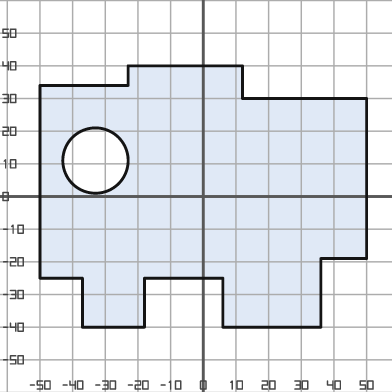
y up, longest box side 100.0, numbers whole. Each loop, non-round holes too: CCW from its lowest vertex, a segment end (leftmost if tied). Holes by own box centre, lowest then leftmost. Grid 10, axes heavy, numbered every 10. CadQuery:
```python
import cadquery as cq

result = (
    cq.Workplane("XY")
    .moveTo(-37.0, -40.0)
    .lineTo(-18.0, -40.0)
    .lineTo(-18.0, -25.0)
    .lineTo(6.0, -25.0)
    .lineTo(6.0, -40.0)
    .lineTo(36.0, -40.0)
    .lineTo(36.0, -19.0)
    .lineTo(50.0, -19.0)
    .lineTo(50.0, 30.0)
    .lineTo(12.0, 30.0)
    .lineTo(12.0, 40.0)
    .lineTo(-23.0, 40.0)
    .lineTo(-23.0, 34.0)
    .lineTo(-50.0, 34.0)
    .lineTo(-50.0, -25.0)
    .lineTo(-37.0, -25.0)
    .close()
    .moveTo(-33.0, 11.0)
    .circle(10.0)
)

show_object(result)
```